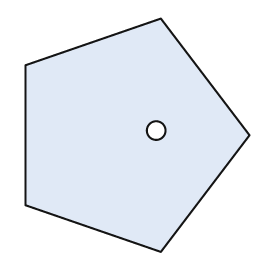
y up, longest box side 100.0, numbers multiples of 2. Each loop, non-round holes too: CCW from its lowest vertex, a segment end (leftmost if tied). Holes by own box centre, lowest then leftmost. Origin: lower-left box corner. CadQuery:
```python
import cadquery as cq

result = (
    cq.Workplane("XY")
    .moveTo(58.0, 0.0)
    .lineTo(96.0, 50.0)
    .lineTo(58.0, 100.0)
    .lineTo(0.0, 80.0)
    .lineTo(0.0, 20.0)
    .close()
    .moveTo(56.0, 52.0)
    .circle(4.0)
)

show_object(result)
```